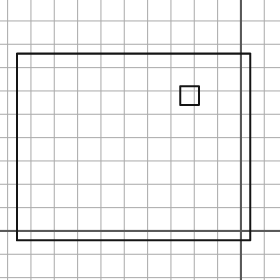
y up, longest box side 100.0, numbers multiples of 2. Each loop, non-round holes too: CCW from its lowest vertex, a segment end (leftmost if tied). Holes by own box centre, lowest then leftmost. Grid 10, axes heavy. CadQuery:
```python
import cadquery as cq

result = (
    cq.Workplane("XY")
    .moveTo(-96.0, -4.0)
    .lineTo(4.0, -4.0)
    .lineTo(4.0, 76.0)
    .lineTo(-96.0, 76.0)
    .close()
    .moveTo(-26.0, 54.0)
    .lineTo(-18.0, 54.0)
    .lineTo(-18.0, 62.0)
    .lineTo(-26.0, 62.0)
    .close()
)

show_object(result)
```